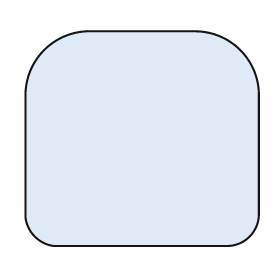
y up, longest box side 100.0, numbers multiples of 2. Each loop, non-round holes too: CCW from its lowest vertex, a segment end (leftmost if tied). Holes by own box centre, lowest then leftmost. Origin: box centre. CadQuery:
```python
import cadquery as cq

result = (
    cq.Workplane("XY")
    .moveTo(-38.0, -46.0)
    .lineTo(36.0, -46.0)
    .threePointArc((46.0, -42.0), (50.0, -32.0))
    .lineTo(50.0, 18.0)
    .threePointArc((42.0, 38.0), (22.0, 46.0))
    .lineTo(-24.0, 46.0)
    .threePointArc((-42.0, 38.0), (-50.0, 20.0))
    .lineTo(-50.0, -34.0)
    .threePointArc((-46.0, -42.0), (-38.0, -46.0))
    .close()
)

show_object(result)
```